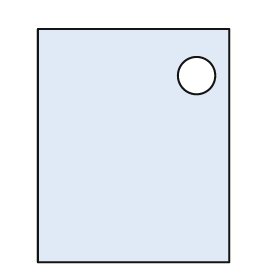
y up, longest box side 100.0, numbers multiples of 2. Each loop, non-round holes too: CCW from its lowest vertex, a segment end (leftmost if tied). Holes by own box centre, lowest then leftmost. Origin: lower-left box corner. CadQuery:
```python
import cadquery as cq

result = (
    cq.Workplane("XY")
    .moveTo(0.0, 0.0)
    .lineTo(82.0, 0.0)
    .lineTo(82.0, 100.0)
    .lineTo(0.0, 100.0)
    .close()
    .moveTo(68.0, 80.0)
    .circle(8.0)
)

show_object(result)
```